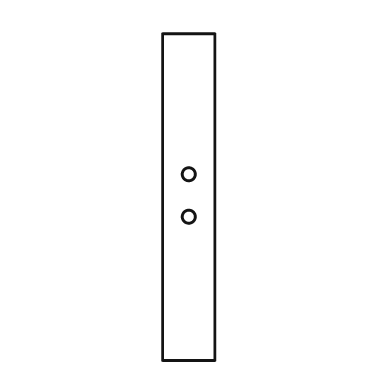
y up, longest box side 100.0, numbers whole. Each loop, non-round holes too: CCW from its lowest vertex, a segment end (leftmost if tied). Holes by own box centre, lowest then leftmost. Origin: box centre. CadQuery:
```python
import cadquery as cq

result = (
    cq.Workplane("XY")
    .moveTo(-8.0, -50.0)
    .lineTo(8.0, -50.0)
    .lineTo(8.0, 50.0)
    .lineTo(-8.0, 50.0)
    .close()
    .moveTo(0.0, -6.0)
    .circle(2.0)
    .moveTo(0.0, 7.0)
    .circle(2.0)
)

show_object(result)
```